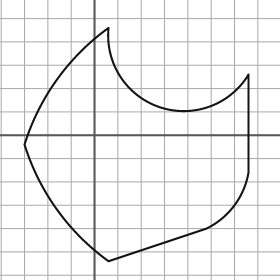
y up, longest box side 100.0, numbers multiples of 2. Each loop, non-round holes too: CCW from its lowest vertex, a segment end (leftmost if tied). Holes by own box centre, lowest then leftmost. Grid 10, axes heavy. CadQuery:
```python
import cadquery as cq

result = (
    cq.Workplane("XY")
    .moveTo(6.0, -54.0)
    .lineTo(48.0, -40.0)
    .threePointArc((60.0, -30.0), (66.0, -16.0))
    .lineTo(66.0, 26.0)
    .threePointArc((28.0, 12.0), (6.0, 46.0))
    .threePointArc((-16.0, 24.0), (-30.0, -4.0))
    .threePointArc((-16.0, -32.0), (6.0, -54.0))
    .close()
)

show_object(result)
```